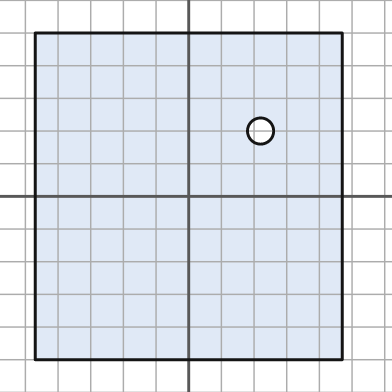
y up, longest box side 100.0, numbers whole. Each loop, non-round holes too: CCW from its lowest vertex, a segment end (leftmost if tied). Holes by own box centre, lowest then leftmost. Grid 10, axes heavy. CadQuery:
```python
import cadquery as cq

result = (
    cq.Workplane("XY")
    .moveTo(-47.0, -50.0)
    .lineTo(47.0, -50.0)
    .lineTo(47.0, 50.0)
    .lineTo(-47.0, 50.0)
    .close()
    .moveTo(22.0, 20.0)
    .circle(4.0)
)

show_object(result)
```